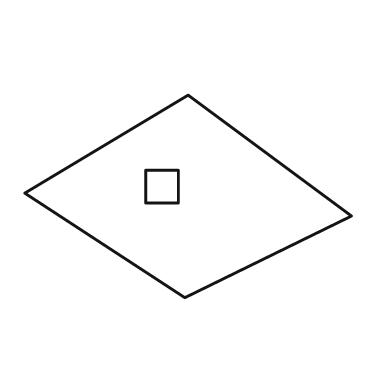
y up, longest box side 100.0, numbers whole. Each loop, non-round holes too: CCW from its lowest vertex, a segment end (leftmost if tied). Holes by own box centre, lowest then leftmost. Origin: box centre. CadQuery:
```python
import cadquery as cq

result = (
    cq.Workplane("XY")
    .moveTo(-1.0, -31.0)
    .lineTo(50.0, -6.0)
    .lineTo(0.0, 31.0)
    .lineTo(-50.0, 1.0)
    .close()
    .moveTo(-13.0, -2.0)
    .lineTo(-3.0, -2.0)
    .lineTo(-3.0, 8.0)
    .lineTo(-13.0, 8.0)
    .close()
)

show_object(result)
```